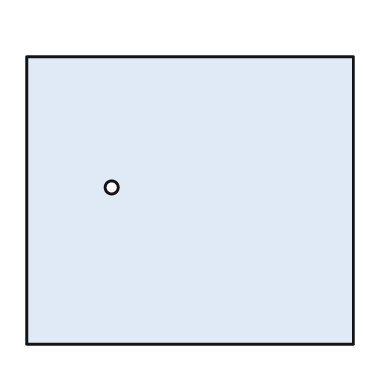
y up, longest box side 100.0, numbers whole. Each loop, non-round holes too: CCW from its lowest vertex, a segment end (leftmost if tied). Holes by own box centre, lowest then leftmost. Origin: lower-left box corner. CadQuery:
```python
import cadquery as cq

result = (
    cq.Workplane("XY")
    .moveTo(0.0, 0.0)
    .lineTo(100.0, 0.0)
    .lineTo(100.0, 88.0)
    .lineTo(0.0, 88.0)
    .close()
    .moveTo(26.0, 48.0)
    .circle(2.0)
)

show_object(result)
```